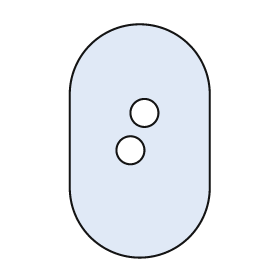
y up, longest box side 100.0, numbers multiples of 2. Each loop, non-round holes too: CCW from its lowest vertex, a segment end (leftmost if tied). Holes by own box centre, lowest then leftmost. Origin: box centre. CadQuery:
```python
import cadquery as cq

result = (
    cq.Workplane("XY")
    .moveTo(-30.0, -20.0)
    .threePointArc((0.0, -50.0), (30.0, -20.0))
    .lineTo(30.0, 20.0)
    .threePointArc((0.0, 50.0), (-30.0, 20.0))
    .close()
    .moveTo(-4.0, -4.0)
    .circle(6.0)
    .moveTo(2.0, 12.0)
    .circle(6.0)
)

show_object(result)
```